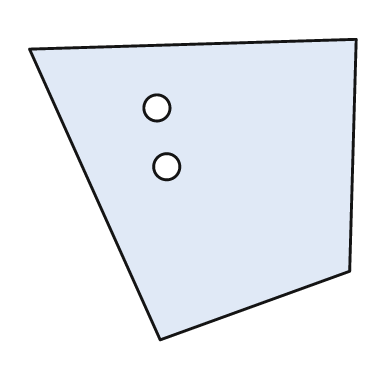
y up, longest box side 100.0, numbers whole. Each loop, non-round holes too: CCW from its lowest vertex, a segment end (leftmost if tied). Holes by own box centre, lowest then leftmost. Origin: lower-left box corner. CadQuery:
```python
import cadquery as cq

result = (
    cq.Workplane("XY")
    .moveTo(40.0, 0.0)
    .lineTo(98.0, 21.0)
    .lineTo(100.0, 92.0)
    .lineTo(0.0, 89.0)
    .close()
    .moveTo(42.0, 53.0)
    .circle(4.0)
    .moveTo(39.0, 71.0)
    .circle(4.0)
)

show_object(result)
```